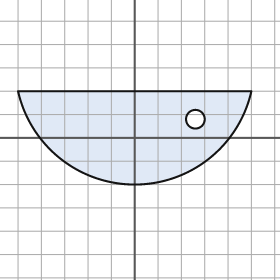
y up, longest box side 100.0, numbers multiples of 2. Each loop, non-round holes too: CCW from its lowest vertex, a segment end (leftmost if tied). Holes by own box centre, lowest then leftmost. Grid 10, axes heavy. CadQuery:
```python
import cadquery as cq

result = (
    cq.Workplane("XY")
    .moveTo(-50.0, 20.0)
    .threePointArc((0.0, -20.0), (50.0, 20.0))
    .close()
    .moveTo(26.0, 8.0)
    .circle(4.0)
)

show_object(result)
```